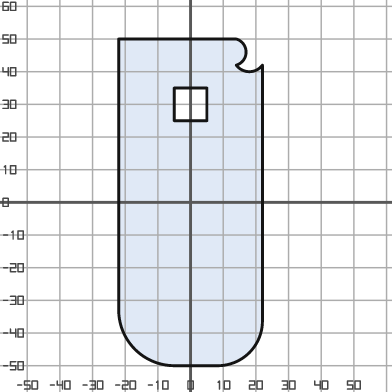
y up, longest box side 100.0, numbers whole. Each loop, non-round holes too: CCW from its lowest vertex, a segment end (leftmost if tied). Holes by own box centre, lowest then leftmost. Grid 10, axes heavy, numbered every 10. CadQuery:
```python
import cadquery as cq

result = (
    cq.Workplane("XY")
    .moveTo(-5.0, -50.0)
    .lineTo(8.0, -50.0)
    .threePointArc((18.0, -46.0), (22.0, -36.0))
    .lineTo(22.0, 42.0)
    .threePointArc((18.0, 40.0), (14.0, 42.0))
    .threePointArc((17.0, 46.0), (14.0, 50.0))
    .lineTo(-22.0, 50.0)
    .lineTo(-22.0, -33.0)
    .threePointArc((-17.0, -45.0), (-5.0, -50.0))
    .close()
    .moveTo(-5.0, 25.0)
    .lineTo(5.0, 25.0)
    .lineTo(5.0, 35.0)
    .lineTo(-5.0, 35.0)
    .close()
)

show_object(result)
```